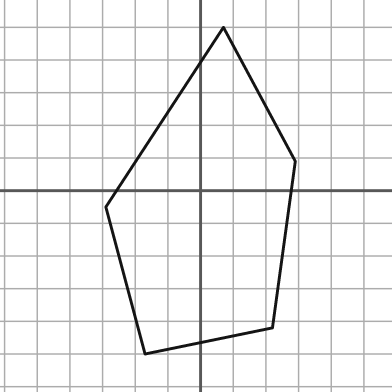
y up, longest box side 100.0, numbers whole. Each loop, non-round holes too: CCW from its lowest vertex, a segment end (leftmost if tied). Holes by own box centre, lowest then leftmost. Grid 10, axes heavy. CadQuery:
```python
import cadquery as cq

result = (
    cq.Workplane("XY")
    .moveTo(-17.0, -50.0)
    .lineTo(22.0, -42.0)
    .lineTo(29.0, 9.0)
    .lineTo(7.0, 50.0)
    .lineTo(-29.0, -5.0)
    .close()
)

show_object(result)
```